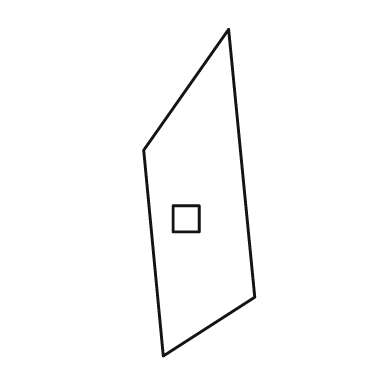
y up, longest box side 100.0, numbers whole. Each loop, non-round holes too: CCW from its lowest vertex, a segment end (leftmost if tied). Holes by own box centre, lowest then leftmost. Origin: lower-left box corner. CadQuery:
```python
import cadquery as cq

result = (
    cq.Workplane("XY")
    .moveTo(6.0, 0.0)
    .lineTo(34.0, 18.0)
    .lineTo(26.0, 100.0)
    .lineTo(0.0, 63.0)
    .close()
    .moveTo(9.0, 38.0)
    .lineTo(17.0, 38.0)
    .lineTo(17.0, 46.0)
    .lineTo(9.0, 46.0)
    .close()
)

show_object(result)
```